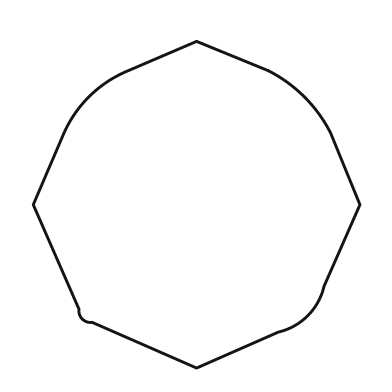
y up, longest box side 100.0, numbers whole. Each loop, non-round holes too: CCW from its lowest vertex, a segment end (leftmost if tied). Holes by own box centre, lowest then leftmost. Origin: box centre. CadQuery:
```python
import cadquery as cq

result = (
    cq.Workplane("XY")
    .moveTo(0.0, -50.0)
    .lineTo(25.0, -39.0)
    .threePointArc((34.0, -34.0), (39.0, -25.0))
    .lineTo(50.0, 0.0)
    .lineTo(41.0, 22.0)
    .threePointArc((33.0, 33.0), (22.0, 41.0))
    .lineTo(0.0, 50.0)
    .lineTo(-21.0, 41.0)
    .threePointArc((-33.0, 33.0), (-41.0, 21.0))
    .lineTo(-50.0, 0.0)
    .lineTo(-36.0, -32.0)
    .threePointArc((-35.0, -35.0), (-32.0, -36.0))
    .close()
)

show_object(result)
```